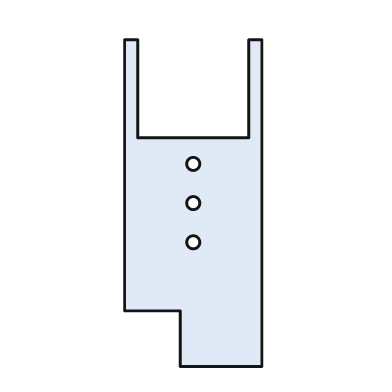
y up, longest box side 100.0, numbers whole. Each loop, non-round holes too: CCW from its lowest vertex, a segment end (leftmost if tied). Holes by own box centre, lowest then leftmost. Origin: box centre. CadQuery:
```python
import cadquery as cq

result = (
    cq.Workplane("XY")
    .moveTo(-4.0, -50.0)
    .lineTo(21.0, -50.0)
    .lineTo(21.0, 50.0)
    .lineTo(17.0, 50.0)
    .lineTo(17.0, 20.0)
    .lineTo(-17.0, 20.0)
    .lineTo(-17.0, 50.0)
    .lineTo(-21.0, 50.0)
    .lineTo(-21.0, -33.0)
    .lineTo(-4.0, -33.0)
    .close()
    .moveTo(0.0, -12.0)
    .circle(2.0)
    .moveTo(0.0, 0.0)
    .circle(2.0)
    .moveTo(0.0, 12.0)
    .circle(2.0)
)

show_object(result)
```